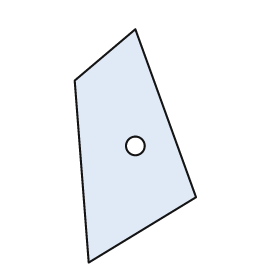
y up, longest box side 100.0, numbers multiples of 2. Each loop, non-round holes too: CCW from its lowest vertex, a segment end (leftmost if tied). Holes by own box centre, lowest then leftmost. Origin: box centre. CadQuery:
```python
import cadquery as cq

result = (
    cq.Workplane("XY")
    .moveTo(-20.0, -50.0)
    .lineTo(26.0, -22.0)
    .lineTo(0.0, 50.0)
    .lineTo(-26.0, 28.0)
    .close()
    .moveTo(0.0, 0.0)
    .circle(4.0)
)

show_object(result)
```